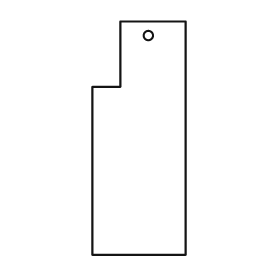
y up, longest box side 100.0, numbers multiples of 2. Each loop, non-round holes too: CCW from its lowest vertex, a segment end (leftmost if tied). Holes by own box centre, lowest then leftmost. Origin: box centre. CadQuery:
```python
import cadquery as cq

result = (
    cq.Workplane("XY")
    .moveTo(-20.0, -50.0)
    .lineTo(20.0, -50.0)
    .lineTo(20.0, 50.0)
    .lineTo(-8.0, 50.0)
    .lineTo(-8.0, 22.0)
    .lineTo(-20.0, 22.0)
    .close()
    .moveTo(4.0, 44.0)
    .circle(2.0)
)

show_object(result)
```